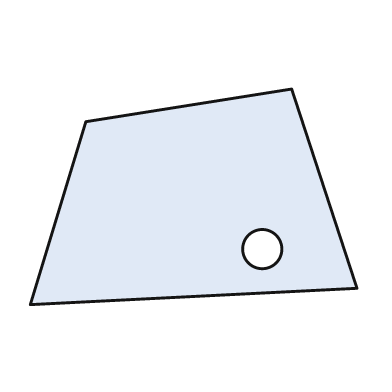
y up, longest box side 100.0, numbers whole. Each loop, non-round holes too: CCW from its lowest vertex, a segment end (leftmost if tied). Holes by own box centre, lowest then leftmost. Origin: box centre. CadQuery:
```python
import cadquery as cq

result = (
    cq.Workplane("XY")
    .moveTo(-50.0, -33.0)
    .lineTo(50.0, -28.0)
    .lineTo(30.0, 33.0)
    .lineTo(-33.0, 23.0)
    .close()
    .moveTo(21.0, -16.0)
    .circle(6.0)
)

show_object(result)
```